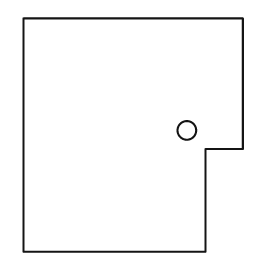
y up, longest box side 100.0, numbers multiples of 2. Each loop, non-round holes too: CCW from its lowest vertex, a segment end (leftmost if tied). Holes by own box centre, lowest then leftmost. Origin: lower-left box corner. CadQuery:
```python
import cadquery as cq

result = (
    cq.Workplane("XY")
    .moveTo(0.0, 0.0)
    .lineTo(78.0, 0.0)
    .lineTo(78.0, 44.0)
    .lineTo(94.0, 44.0)
    .lineTo(94.0, 100.0)
    .lineTo(0.0, 100.0)
    .close()
    .moveTo(70.0, 52.0)
    .circle(4.0)
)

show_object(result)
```